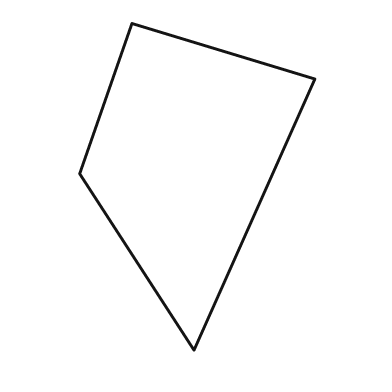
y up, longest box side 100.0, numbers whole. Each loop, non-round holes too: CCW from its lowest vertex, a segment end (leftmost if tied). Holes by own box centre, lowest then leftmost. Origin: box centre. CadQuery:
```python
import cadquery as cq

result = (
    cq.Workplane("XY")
    .moveTo(-1.0, -50.0)
    .lineTo(36.0, 33.0)
    .lineTo(-20.0, 50.0)
    .lineTo(-36.0, 4.0)
    .close()
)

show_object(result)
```